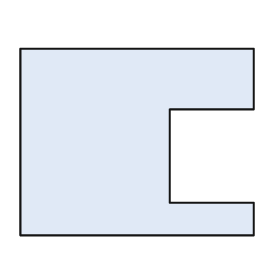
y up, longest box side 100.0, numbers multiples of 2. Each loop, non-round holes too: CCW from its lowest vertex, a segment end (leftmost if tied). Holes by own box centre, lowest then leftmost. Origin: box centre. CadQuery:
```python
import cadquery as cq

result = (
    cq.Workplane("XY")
    .moveTo(-50.0, -40.0)
    .lineTo(50.0, -40.0)
    .lineTo(50.0, -26.0)
    .lineTo(14.0, -26.0)
    .lineTo(14.0, 14.0)
    .lineTo(50.0, 14.0)
    .lineTo(50.0, 40.0)
    .lineTo(-50.0, 40.0)
    .close()
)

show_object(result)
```